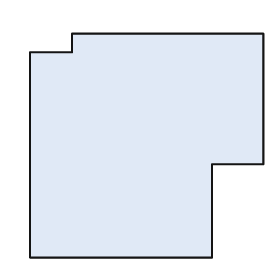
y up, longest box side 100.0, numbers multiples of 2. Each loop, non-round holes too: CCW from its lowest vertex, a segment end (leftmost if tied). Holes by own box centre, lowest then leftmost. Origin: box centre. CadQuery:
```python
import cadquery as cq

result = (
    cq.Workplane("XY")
    .moveTo(-50.0, -48.0)
    .lineTo(28.0, -48.0)
    .lineTo(28.0, -8.0)
    .lineTo(50.0, -8.0)
    .lineTo(50.0, 48.0)
    .lineTo(-32.0, 48.0)
    .lineTo(-32.0, 40.0)
    .lineTo(-50.0, 40.0)
    .close()
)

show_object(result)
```